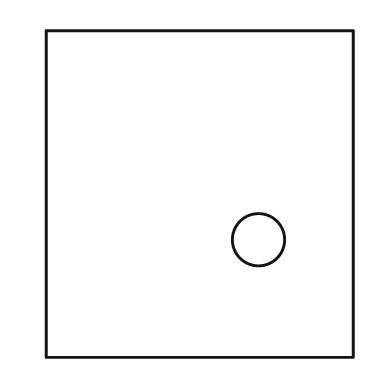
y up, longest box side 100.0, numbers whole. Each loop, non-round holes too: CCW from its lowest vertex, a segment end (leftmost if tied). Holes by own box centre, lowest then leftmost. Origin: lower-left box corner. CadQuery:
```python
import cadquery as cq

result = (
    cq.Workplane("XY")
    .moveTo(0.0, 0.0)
    .lineTo(94.0, 0.0)
    .lineTo(94.0, 100.0)
    .lineTo(0.0, 100.0)
    .close()
    .moveTo(65.0, 36.0)
    .circle(8.0)
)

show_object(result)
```